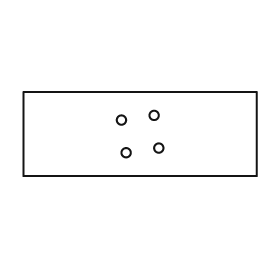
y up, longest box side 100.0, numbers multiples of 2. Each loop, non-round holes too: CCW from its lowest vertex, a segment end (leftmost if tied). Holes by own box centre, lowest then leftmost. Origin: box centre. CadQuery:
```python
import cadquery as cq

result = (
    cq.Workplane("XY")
    .moveTo(-50.0, -18.0)
    .lineTo(50.0, -18.0)
    .lineTo(50.0, 18.0)
    .lineTo(-50.0, 18.0)
    .close()
    .moveTo(-6.0, -8.0)
    .circle(2.0)
    .moveTo(8.0, -6.0)
    .circle(2.0)
    .moveTo(-8.0, 6.0)
    .circle(2.0)
    .moveTo(6.0, 8.0)
    .circle(2.0)
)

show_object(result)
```